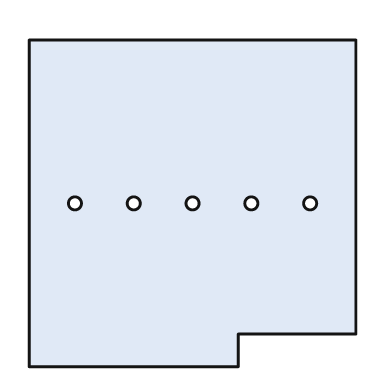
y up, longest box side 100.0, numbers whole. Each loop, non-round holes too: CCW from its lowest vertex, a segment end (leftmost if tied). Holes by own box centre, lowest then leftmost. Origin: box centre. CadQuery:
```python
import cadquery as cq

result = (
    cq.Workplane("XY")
    .moveTo(-50.0, -50.0)
    .lineTo(14.0, -50.0)
    .lineTo(14.0, -40.0)
    .lineTo(50.0, -40.0)
    .lineTo(50.0, 50.0)
    .lineTo(-50.0, 50.0)
    .close()
    .moveTo(-36.0, 0.0)
    .circle(2.0)
    .moveTo(-18.0, 0.0)
    .circle(2.0)
    .moveTo(0.0, 0.0)
    .circle(2.0)
    .moveTo(18.0, 0.0)
    .circle(2.0)
    .moveTo(36.0, 0.0)
    .circle(2.0)
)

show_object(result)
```